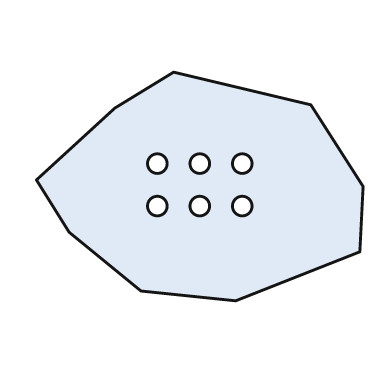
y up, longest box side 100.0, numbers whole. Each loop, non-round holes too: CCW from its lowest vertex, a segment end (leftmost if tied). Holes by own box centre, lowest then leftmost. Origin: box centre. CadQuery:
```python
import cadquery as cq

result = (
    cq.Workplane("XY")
    .moveTo(11.0, -35.0)
    .lineTo(49.0, -20.0)
    .lineTo(50.0, 0.0)
    .lineTo(34.0, 25.0)
    .lineTo(-8.0, 35.0)
    .lineTo(-26.0, 24.0)
    .lineTo(-50.0, 2.0)
    .lineTo(-40.0, -14.0)
    .lineTo(-18.0, -32.0)
    .close()
    .moveTo(-13.0, -6.0)
    .circle(3.0)
    .moveTo(0.0, -6.0)
    .circle(3.0)
    .moveTo(13.0, -6.0)
    .circle(3.0)
    .moveTo(-13.0, 7.0)
    .circle(3.0)
    .moveTo(0.0, 7.0)
    .circle(3.0)
    .moveTo(13.0, 7.0)
    .circle(3.0)
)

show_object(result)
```